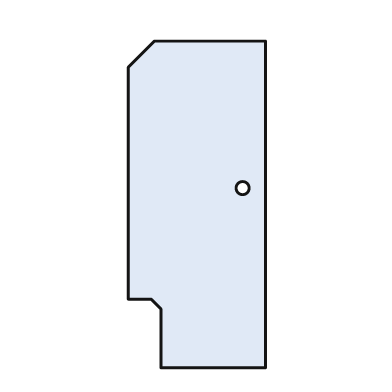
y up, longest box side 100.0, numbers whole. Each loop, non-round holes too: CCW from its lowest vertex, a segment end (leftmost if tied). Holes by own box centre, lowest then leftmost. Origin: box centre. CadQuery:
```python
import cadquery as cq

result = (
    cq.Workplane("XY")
    .moveTo(-11.0, -50.0)
    .lineTo(21.0, -50.0)
    .lineTo(21.0, 50.0)
    .lineTo(-13.0, 50.0)
    .lineTo(-21.0, 42.0)
    .lineTo(-21.0, -29.0)
    .lineTo(-14.0, -29.0)
    .lineTo(-11.0, -32.0)
    .close()
    .moveTo(14.0, 5.0)
    .circle(2.0)
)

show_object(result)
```